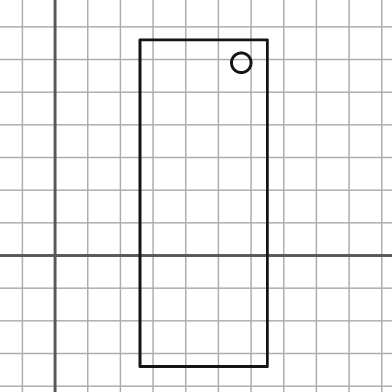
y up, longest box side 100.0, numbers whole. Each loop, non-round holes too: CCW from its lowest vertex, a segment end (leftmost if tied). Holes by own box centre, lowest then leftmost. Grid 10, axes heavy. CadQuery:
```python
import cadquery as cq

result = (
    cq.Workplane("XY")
    .moveTo(26.0, -34.0)
    .lineTo(65.0, -34.0)
    .lineTo(65.0, 66.0)
    .lineTo(26.0, 66.0)
    .close()
    .moveTo(57.0, 59.0)
    .circle(3.0)
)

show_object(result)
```